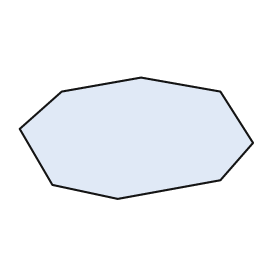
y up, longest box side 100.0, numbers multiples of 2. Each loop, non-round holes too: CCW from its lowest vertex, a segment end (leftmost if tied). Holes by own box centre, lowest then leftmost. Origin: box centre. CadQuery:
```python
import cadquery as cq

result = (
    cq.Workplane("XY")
    .moveTo(-8.0, -26.0)
    .lineTo(36.0, -18.0)
    .lineTo(50.0, -2.0)
    .lineTo(36.0, 20.0)
    .lineTo(2.0, 26.0)
    .lineTo(-32.0, 20.0)
    .lineTo(-50.0, 4.0)
    .lineTo(-36.0, -20.0)
    .close()
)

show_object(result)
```